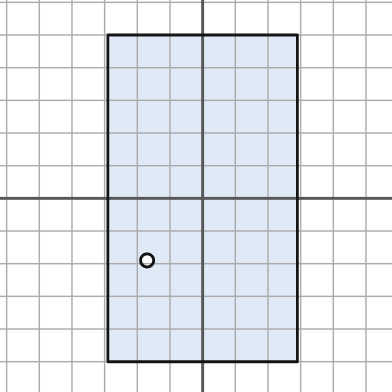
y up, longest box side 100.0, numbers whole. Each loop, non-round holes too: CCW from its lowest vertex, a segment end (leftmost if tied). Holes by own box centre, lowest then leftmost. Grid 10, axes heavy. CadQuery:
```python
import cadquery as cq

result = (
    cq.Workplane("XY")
    .moveTo(-29.0, -50.0)
    .lineTo(29.0, -50.0)
    .lineTo(29.0, 50.0)
    .lineTo(-29.0, 50.0)
    .close()
    .moveTo(-17.0, -19.0)
    .circle(2.0)
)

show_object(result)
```